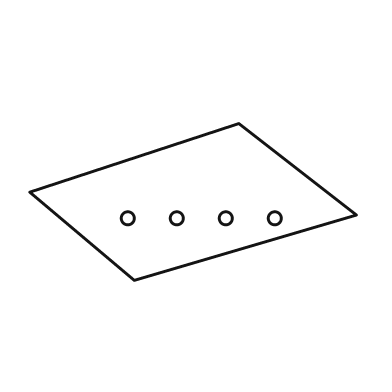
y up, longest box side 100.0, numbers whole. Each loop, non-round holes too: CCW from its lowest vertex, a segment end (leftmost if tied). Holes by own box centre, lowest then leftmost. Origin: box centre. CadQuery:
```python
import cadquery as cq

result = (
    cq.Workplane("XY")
    .moveTo(-18.0, -24.0)
    .lineTo(50.0, -4.0)
    .lineTo(14.0, 24.0)
    .lineTo(-50.0, 3.0)
    .close()
    .moveTo(-20.0, -5.0)
    .circle(2.0)
    .moveTo(-5.0, -5.0)
    .circle(2.0)
    .moveTo(10.0, -5.0)
    .circle(2.0)
    .moveTo(25.0, -5.0)
    .circle(2.0)
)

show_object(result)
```